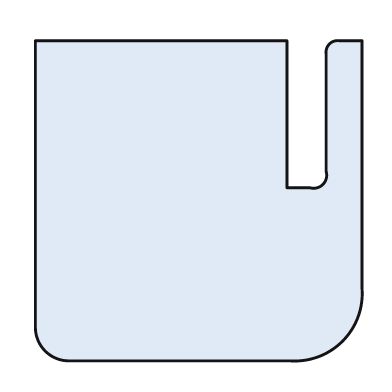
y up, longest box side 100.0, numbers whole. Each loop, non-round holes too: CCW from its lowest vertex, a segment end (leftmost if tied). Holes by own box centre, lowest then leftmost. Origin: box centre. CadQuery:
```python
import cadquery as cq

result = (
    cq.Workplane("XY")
    .moveTo(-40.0, -49.0)
    .lineTo(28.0, -49.0)
    .threePointArc((44.0, -43.0), (50.0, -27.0))
    .lineTo(50.0, 49.0)
    .lineTo(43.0, 49.0)
    .threePointArc((40.0, 48.0), (39.0, 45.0))
    .lineTo(39.0, 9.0)
    .threePointArc((38.0, 5.0), (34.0, 4.0))
    .lineTo(27.0, 4.0)
    .lineTo(27.0, 49.0)
    .lineTo(-50.0, 49.0)
    .lineTo(-50.0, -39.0)
    .threePointArc((-47.0, -46.0), (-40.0, -49.0))
    .close()
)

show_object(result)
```